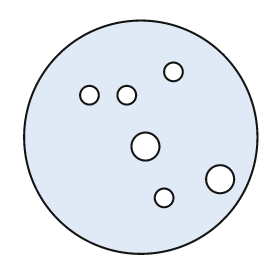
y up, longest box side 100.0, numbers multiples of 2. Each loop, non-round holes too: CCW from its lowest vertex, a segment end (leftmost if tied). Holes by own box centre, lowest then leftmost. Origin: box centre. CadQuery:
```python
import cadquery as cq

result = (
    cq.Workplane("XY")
    .moveTo(0.0, 0.0)
    .circle(50.0)
    .moveTo(10.0, -26.0)
    .circle(4.0)
    .moveTo(34.0, -18.0)
    .circle(6.0)
    .moveTo(2.0, -4.0)
    .circle(6.0)
    .moveTo(-22.0, 18.0)
    .circle(4.0)
    .moveTo(-6.0, 18.0)
    .circle(4.0)
    .moveTo(14.0, 28.0)
    .circle(4.0)
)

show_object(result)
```